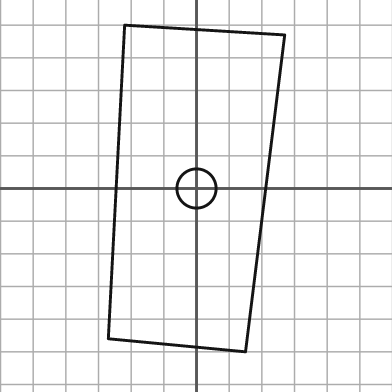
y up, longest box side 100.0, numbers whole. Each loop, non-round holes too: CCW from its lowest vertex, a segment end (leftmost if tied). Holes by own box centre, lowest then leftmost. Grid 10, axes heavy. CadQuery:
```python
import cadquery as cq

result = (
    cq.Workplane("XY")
    .moveTo(15.0, -50.0)
    .lineTo(27.0, 47.0)
    .lineTo(-22.0, 50.0)
    .lineTo(-27.0, -46.0)
    .close()
    .moveTo(0.0, 0.0)
    .circle(6.0)
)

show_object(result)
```